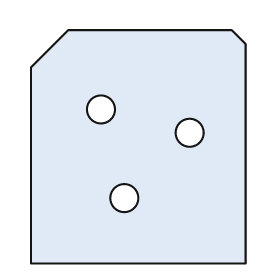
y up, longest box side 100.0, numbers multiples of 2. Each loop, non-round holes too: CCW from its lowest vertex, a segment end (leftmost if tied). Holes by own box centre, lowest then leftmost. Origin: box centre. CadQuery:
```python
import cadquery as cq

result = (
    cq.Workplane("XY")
    .moveTo(-46.0, -50.0)
    .lineTo(46.0, -50.0)
    .lineTo(46.0, 44.0)
    .lineTo(40.0, 50.0)
    .lineTo(-30.0, 50.0)
    .lineTo(-46.0, 34.0)
    .close()
    .moveTo(-6.0, -22.0)
    .circle(6.0)
    .moveTo(22.0, 6.0)
    .circle(6.0)
    .moveTo(-16.0, 16.0)
    .circle(6.0)
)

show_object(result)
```